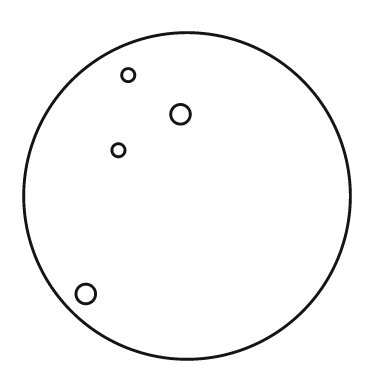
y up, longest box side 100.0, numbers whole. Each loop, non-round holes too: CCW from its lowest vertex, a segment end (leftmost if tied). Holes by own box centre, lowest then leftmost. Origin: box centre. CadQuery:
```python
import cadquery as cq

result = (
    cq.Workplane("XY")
    .moveTo(0.0, 0.0)
    .circle(50.0)
    .moveTo(-31.0, -30.0)
    .circle(3.0)
    .moveTo(-21.0, 14.0)
    .circle(2.0)
    .moveTo(-2.0, 25.0)
    .circle(3.0)
    .moveTo(-18.0, 37.0)
    .circle(2.0)
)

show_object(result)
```